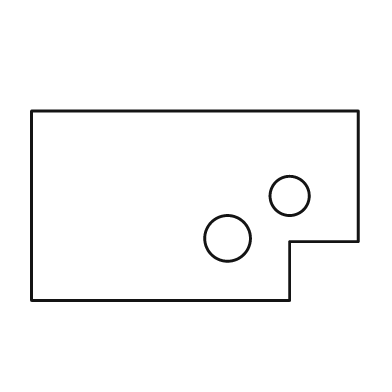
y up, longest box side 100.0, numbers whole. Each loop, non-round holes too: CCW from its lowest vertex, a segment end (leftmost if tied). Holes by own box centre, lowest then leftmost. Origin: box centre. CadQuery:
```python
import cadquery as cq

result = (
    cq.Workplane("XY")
    .moveTo(-50.0, -29.0)
    .lineTo(29.0, -29.0)
    .lineTo(29.0, -11.0)
    .lineTo(50.0, -11.0)
    .lineTo(50.0, 29.0)
    .lineTo(-50.0, 29.0)
    .close()
    .moveTo(10.0, -10.0)
    .circle(7.0)
    .moveTo(29.0, 3.0)
    .circle(6.0)
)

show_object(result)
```